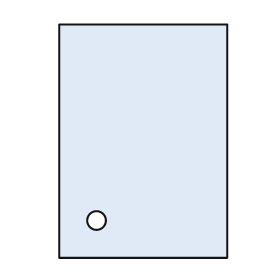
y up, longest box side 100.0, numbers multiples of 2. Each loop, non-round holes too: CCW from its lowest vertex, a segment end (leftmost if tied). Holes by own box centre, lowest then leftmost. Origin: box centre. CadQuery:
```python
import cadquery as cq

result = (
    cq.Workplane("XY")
    .moveTo(-36.0, -50.0)
    .lineTo(36.0, -50.0)
    .lineTo(36.0, 50.0)
    .lineTo(-36.0, 50.0)
    .close()
    .moveTo(-20.0, -34.0)
    .circle(4.0)
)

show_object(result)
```